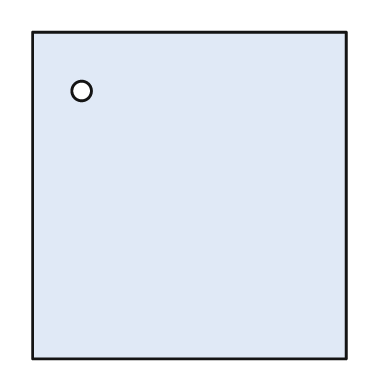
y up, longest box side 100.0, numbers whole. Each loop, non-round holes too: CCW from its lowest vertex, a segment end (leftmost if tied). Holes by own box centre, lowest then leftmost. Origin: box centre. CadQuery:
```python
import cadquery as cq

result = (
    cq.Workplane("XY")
    .moveTo(-48.0, -50.0)
    .lineTo(48.0, -50.0)
    .lineTo(48.0, 50.0)
    .lineTo(-48.0, 50.0)
    .close()
    .moveTo(-33.0, 32.0)
    .circle(3.0)
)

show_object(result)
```